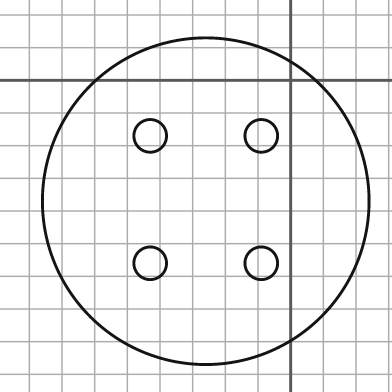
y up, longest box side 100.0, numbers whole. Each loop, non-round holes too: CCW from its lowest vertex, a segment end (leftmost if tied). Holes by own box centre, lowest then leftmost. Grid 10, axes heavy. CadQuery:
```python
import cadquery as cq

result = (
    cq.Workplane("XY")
    .moveTo(-26.0, -37.0)
    .circle(50.0)
    .moveTo(-43.0, -56.0)
    .circle(5.0)
    .moveTo(-9.0, -56.0)
    .circle(5.0)
    .moveTo(-43.0, -17.0)
    .circle(5.0)
    .moveTo(-9.0, -17.0)
    .circle(5.0)
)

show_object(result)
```